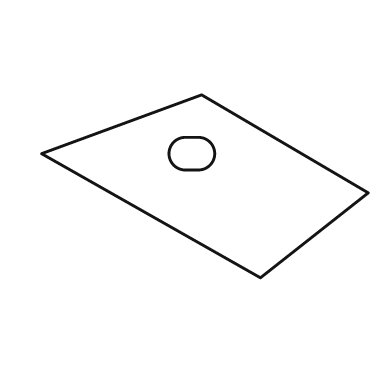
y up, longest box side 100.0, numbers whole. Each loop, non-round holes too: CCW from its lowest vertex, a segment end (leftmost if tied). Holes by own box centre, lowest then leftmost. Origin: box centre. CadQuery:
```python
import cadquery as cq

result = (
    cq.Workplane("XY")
    .moveTo(17.0, -28.0)
    .lineTo(50.0, -2.0)
    .lineTo(-1.0, 28.0)
    .lineTo(-50.0, 10.0)
    .close()
    .moveTo(-6.0, 5.0)
    .lineTo(-2.0, 5.0)
    .threePointArc((3.0, 10.0), (-2.0, 15.0))
    .lineTo(-6.0, 15.0)
    .threePointArc((-11.0, 10.0), (-6.0, 5.0))
    .close()
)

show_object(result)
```